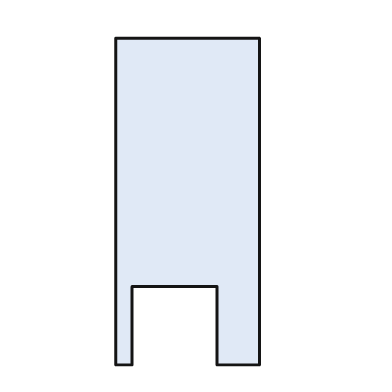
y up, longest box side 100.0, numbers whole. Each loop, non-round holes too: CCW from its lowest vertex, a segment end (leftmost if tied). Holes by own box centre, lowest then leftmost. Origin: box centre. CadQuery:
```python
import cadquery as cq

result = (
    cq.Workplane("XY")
    .moveTo(-22.0, -50.0)
    .lineTo(-17.0, -50.0)
    .lineTo(-17.0, -26.0)
    .lineTo(9.0, -26.0)
    .lineTo(9.0, -50.0)
    .lineTo(22.0, -50.0)
    .lineTo(22.0, 50.0)
    .lineTo(-22.0, 50.0)
    .close()
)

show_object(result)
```